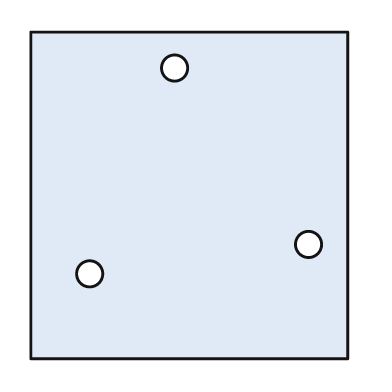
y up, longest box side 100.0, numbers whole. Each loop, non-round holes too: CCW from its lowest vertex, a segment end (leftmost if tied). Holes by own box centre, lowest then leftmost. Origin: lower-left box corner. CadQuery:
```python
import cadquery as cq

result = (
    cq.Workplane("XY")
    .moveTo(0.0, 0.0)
    .lineTo(97.0, 0.0)
    .lineTo(97.0, 100.0)
    .lineTo(0.0, 100.0)
    .close()
    .moveTo(18.0, 26.0)
    .circle(4.0)
    .moveTo(85.0, 35.0)
    .circle(4.0)
    .moveTo(44.0, 89.0)
    .circle(4.0)
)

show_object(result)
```